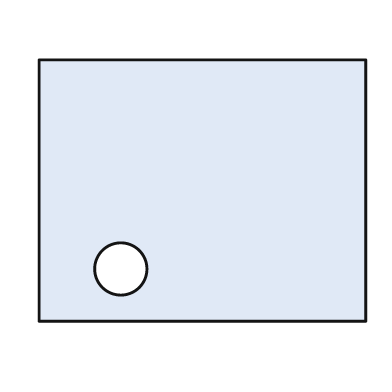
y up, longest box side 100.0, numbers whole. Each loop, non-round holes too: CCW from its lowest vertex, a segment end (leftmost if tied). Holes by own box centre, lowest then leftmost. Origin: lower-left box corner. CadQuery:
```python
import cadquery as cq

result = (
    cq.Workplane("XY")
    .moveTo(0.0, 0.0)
    .lineTo(100.0, 0.0)
    .lineTo(100.0, 80.0)
    .lineTo(0.0, 80.0)
    .close()
    .moveTo(25.0, 16.0)
    .circle(8.0)
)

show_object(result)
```